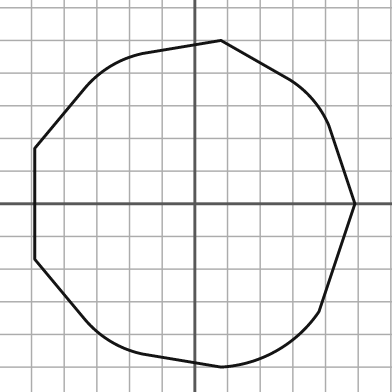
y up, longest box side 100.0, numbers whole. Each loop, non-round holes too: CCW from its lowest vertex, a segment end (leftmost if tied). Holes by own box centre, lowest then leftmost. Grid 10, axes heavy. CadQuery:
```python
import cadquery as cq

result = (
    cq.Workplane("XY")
    .moveTo(8.0, -50.0)
    .threePointArc((25.0, -45.0), (38.0, -33.0))
    .lineTo(49.0, 0.0)
    .lineTo(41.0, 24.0)
    .threePointArc((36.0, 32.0), (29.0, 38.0))
    .lineTo(8.0, 50.0)
    .lineTo(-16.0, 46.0)
    .threePointArc((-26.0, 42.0), (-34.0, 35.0))
    .lineTo(-49.0, 17.0)
    .lineTo(-49.0, -17.0)
    .lineTo(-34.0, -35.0)
    .threePointArc((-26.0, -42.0), (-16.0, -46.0))
    .close()
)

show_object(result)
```